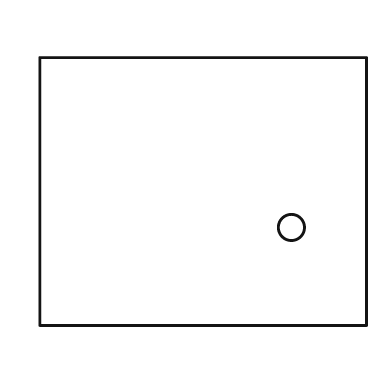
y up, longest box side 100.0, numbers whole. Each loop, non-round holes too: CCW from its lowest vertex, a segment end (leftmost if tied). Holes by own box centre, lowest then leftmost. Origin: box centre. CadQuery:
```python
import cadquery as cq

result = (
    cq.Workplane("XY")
    .moveTo(-50.0, -41.0)
    .lineTo(50.0, -41.0)
    .lineTo(50.0, 41.0)
    .lineTo(-50.0, 41.0)
    .close()
    .moveTo(27.0, -11.0)
    .circle(4.0)
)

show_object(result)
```